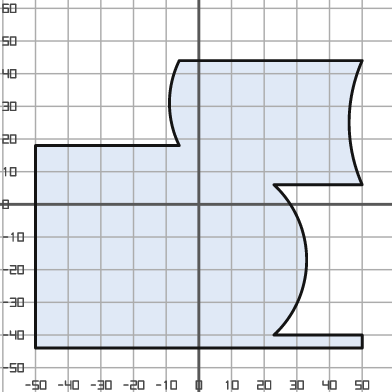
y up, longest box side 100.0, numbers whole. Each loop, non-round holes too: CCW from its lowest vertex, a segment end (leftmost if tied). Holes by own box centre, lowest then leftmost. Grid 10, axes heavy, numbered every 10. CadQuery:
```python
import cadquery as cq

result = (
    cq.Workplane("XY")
    .moveTo(-50.0, -44.0)
    .lineTo(50.0, -44.0)
    .lineTo(50.0, -40.0)
    .lineTo(23.0, -40.0)
    .threePointArc((33.0, -17.0), (23.0, 6.0))
    .lineTo(50.0, 6.0)
    .threePointArc((46.0, 25.0), (50.0, 44.0))
    .lineTo(-6.0, 44.0)
    .threePointArc((-9.0, 31.0), (-6.0, 18.0))
    .lineTo(-50.0, 18.0)
    .close()
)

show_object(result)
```